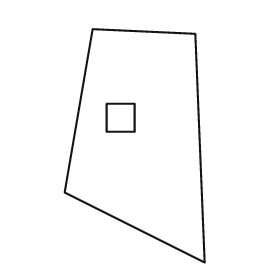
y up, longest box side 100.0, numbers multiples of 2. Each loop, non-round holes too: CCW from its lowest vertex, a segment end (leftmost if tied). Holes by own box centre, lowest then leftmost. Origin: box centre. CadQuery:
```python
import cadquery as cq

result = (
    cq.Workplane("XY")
    .moveTo(30.0, -50.0)
    .lineTo(26.0, 48.0)
    .lineTo(-18.0, 50.0)
    .lineTo(-30.0, -20.0)
    .close()
    .moveTo(-12.0, 6.0)
    .lineTo(0.0, 6.0)
    .lineTo(0.0, 18.0)
    .lineTo(-12.0, 18.0)
    .close()
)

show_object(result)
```